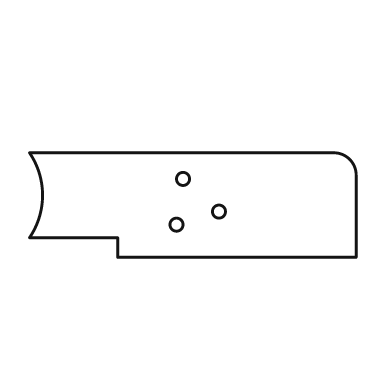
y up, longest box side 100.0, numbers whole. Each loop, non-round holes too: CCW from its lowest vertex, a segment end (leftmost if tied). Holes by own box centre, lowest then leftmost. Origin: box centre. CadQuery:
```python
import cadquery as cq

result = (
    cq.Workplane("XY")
    .moveTo(-23.0, -16.0)
    .lineTo(50.0, -16.0)
    .lineTo(50.0, 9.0)
    .threePointArc((48.0, 14.0), (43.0, 16.0))
    .lineTo(-50.0, 16.0)
    .threePointArc((-46.0, 3.0), (-50.0, -10.0))
    .lineTo(-23.0, -10.0)
    .close()
    .moveTo(-5.0, -6.0)
    .circle(2.0)
    .moveTo(8.0, -2.0)
    .circle(2.0)
    .moveTo(-3.0, 8.0)
    .circle(2.0)
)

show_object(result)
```